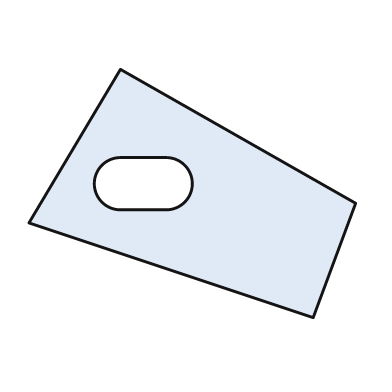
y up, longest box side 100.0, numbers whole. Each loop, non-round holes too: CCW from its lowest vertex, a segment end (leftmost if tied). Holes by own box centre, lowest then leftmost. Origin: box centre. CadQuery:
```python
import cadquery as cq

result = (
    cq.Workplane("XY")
    .moveTo(37.0, -38.0)
    .lineTo(50.0, -3.0)
    .lineTo(-22.0, 38.0)
    .lineTo(-50.0, -9.0)
    .close()
    .moveTo(-22.0, -5.0)
    .lineTo(-8.0, -5.0)
    .threePointArc((0.0, 3.0), (-8.0, 11.0))
    .lineTo(-22.0, 11.0)
    .threePointArc((-30.0, 3.0), (-22.0, -5.0))
    .close()
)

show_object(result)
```